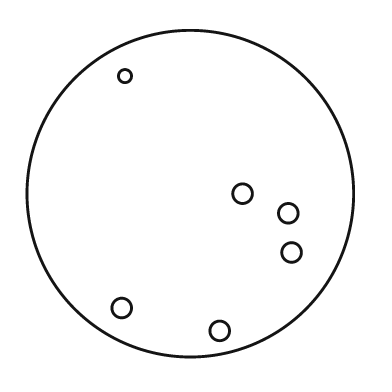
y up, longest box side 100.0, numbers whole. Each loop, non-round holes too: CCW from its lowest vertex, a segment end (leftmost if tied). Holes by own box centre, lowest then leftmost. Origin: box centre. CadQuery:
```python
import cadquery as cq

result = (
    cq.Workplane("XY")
    .moveTo(0.0, 0.0)
    .circle(50.0)
    .moveTo(9.0, -42.0)
    .circle(3.0)
    .moveTo(-21.0, -35.0)
    .circle(3.0)
    .moveTo(31.0, -18.0)
    .circle(3.0)
    .moveTo(30.0, -6.0)
    .circle(3.0)
    .moveTo(16.0, 0.0)
    .circle(3.0)
    .moveTo(-20.0, 36.0)
    .circle(2.0)
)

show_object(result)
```